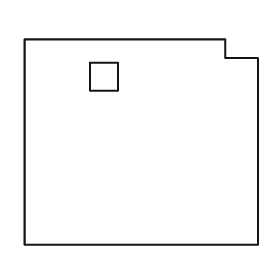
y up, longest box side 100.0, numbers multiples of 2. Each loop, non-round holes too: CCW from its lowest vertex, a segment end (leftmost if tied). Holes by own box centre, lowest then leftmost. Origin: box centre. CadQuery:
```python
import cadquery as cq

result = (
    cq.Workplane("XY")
    .moveTo(-50.0, -44.0)
    .lineTo(50.0, -44.0)
    .lineTo(50.0, 36.0)
    .lineTo(36.0, 36.0)
    .lineTo(36.0, 44.0)
    .lineTo(-50.0, 44.0)
    .close()
    .moveTo(-22.0, 22.0)
    .lineTo(-10.0, 22.0)
    .lineTo(-10.0, 34.0)
    .lineTo(-22.0, 34.0)
    .close()
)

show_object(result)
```